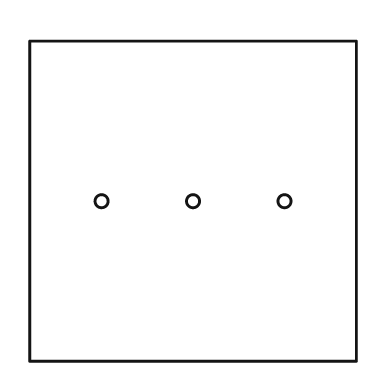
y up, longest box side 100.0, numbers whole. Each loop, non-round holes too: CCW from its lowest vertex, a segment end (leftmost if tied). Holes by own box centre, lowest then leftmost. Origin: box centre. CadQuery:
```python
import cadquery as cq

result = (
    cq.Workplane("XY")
    .moveTo(-50.0, -49.0)
    .lineTo(50.0, -49.0)
    .lineTo(50.0, 49.0)
    .lineTo(-50.0, 49.0)
    .close()
    .moveTo(-28.0, 0.0)
    .circle(2.0)
    .moveTo(0.0, 0.0)
    .circle(2.0)
    .moveTo(28.0, 0.0)
    .circle(2.0)
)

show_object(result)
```